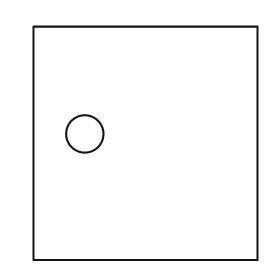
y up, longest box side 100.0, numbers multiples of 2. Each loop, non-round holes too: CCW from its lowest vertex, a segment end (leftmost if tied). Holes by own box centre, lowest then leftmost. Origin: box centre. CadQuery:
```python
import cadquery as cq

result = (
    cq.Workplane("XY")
    .moveTo(-48.0, -50.0)
    .lineTo(48.0, -50.0)
    .lineTo(48.0, 50.0)
    .lineTo(-48.0, 50.0)
    .close()
    .moveTo(-26.0, 4.0)
    .circle(8.0)
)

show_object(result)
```